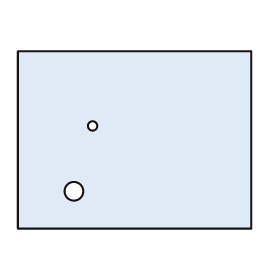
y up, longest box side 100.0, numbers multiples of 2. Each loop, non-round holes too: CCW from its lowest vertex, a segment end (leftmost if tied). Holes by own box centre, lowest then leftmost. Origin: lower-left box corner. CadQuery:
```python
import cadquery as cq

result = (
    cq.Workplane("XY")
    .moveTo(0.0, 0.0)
    .lineTo(100.0, 0.0)
    .lineTo(100.0, 76.0)
    .lineTo(0.0, 76.0)
    .close()
    .moveTo(24.0, 16.0)
    .circle(4.0)
    .moveTo(32.0, 44.0)
    .circle(2.0)
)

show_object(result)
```